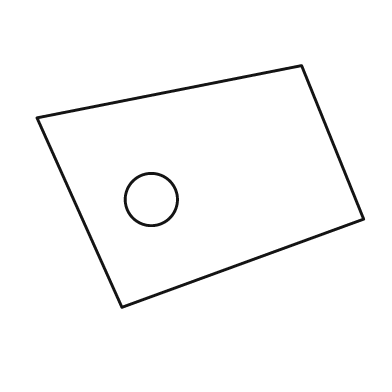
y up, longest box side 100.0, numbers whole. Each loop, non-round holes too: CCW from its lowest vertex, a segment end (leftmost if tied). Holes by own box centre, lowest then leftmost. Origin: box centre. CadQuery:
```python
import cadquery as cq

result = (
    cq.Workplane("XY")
    .moveTo(-24.0, -37.0)
    .lineTo(50.0, -10.0)
    .lineTo(31.0, 37.0)
    .lineTo(-50.0, 21.0)
    .close()
    .moveTo(-15.0, -4.0)
    .circle(8.0)
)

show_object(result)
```